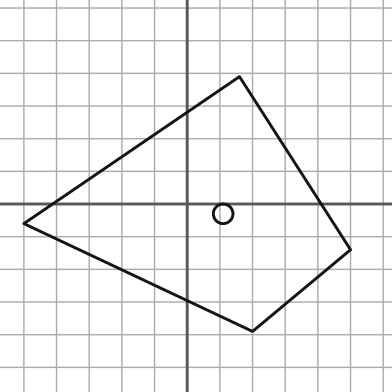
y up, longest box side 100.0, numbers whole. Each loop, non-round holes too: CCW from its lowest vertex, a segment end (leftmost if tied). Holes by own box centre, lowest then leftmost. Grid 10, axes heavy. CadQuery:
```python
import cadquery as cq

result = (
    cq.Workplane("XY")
    .moveTo(20.0, -39.0)
    .lineTo(50.0, -14.0)
    .lineTo(16.0, 39.0)
    .lineTo(-50.0, -6.0)
    .close()
    .moveTo(11.0, -3.0)
    .circle(3.0)
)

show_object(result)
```